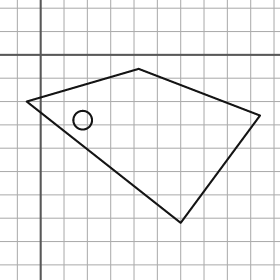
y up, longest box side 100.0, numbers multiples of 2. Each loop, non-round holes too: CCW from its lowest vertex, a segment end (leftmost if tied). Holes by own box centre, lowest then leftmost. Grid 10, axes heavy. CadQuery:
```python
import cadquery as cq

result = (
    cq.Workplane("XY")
    .moveTo(60.0, -72.0)
    .lineTo(94.0, -26.0)
    .lineTo(42.0, -6.0)
    .lineTo(-6.0, -20.0)
    .close()
    .moveTo(18.0, -28.0)
    .circle(4.0)
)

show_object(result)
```